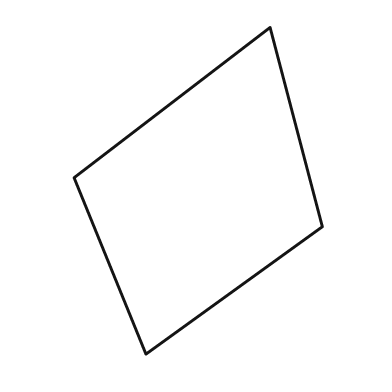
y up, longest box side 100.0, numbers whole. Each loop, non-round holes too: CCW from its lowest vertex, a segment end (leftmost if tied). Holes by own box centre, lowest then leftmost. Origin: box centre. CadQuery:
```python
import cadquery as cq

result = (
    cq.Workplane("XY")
    .moveTo(-16.0, -50.0)
    .lineTo(38.0, -11.0)
    .lineTo(22.0, 50.0)
    .lineTo(-38.0, 4.0)
    .close()
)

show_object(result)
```